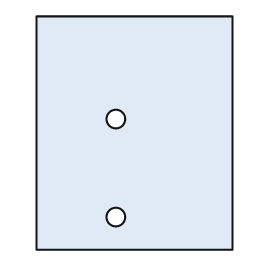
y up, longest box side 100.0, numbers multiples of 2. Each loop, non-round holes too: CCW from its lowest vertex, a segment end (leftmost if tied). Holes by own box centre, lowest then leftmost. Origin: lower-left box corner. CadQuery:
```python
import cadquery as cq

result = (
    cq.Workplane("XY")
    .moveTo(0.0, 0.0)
    .lineTo(84.0, 0.0)
    .lineTo(84.0, 100.0)
    .lineTo(0.0, 100.0)
    .close()
    .moveTo(34.0, 14.0)
    .circle(4.0)
    .moveTo(34.0, 56.0)
    .circle(4.0)
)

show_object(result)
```